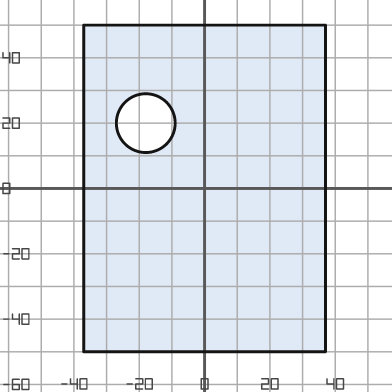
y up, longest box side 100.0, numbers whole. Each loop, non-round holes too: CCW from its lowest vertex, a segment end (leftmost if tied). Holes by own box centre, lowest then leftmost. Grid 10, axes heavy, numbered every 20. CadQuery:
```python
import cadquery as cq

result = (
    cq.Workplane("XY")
    .moveTo(-37.0, -50.0)
    .lineTo(37.0, -50.0)
    .lineTo(37.0, 50.0)
    .lineTo(-37.0, 50.0)
    .close()
    .moveTo(-18.0, 20.0)
    .circle(9.0)
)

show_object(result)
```